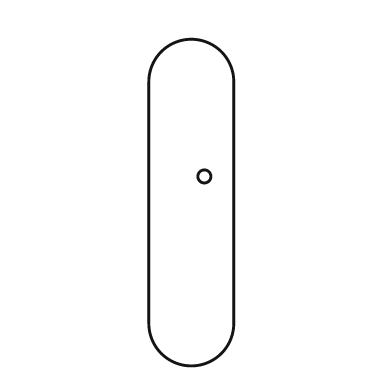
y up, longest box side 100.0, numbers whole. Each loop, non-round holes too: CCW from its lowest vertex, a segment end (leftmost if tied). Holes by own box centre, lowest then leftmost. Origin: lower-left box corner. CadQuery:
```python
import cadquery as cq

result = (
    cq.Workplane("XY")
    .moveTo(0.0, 13.0)
    .threePointArc((13.0, 0.0), (26.0, 13.0))
    .lineTo(26.0, 87.0)
    .threePointArc((13.0, 100.0), (0.0, 87.0))
    .close()
    .moveTo(17.0, 58.0)
    .circle(2.0)
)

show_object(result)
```